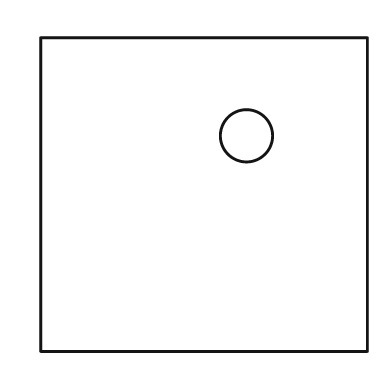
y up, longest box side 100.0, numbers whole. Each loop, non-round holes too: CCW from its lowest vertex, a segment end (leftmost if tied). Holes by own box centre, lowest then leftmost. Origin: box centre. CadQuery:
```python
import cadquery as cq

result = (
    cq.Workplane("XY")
    .moveTo(-50.0, -48.0)
    .lineTo(50.0, -48.0)
    .lineTo(50.0, 48.0)
    .lineTo(-50.0, 48.0)
    .close()
    .moveTo(13.0, 18.0)
    .circle(8.0)
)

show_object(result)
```